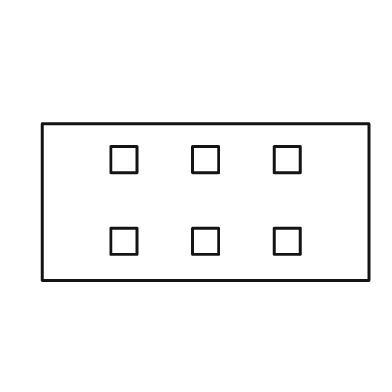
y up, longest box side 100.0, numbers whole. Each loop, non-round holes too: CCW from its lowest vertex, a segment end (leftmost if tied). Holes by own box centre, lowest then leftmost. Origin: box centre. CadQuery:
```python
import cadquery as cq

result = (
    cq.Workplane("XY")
    .moveTo(-50.0, -24.0)
    .lineTo(50.0, -24.0)
    .lineTo(50.0, 24.0)
    .lineTo(-50.0, 24.0)
    .close()
    .moveTo(-29.0, -16.0)
    .lineTo(-21.0, -16.0)
    .lineTo(-21.0, -8.0)
    .lineTo(-29.0, -8.0)
    .close()
    .moveTo(-4.0, -16.0)
    .lineTo(4.0, -16.0)
    .lineTo(4.0, -8.0)
    .lineTo(-4.0, -8.0)
    .close()
    .moveTo(21.0, -16.0)
    .lineTo(29.0, -16.0)
    .lineTo(29.0, -8.0)
    .lineTo(21.0, -8.0)
    .close()
    .moveTo(-29.0, 9.0)
    .lineTo(-21.0, 9.0)
    .lineTo(-21.0, 17.0)
    .lineTo(-29.0, 17.0)
    .close()
    .moveTo(-4.0, 9.0)
    .lineTo(4.0, 9.0)
    .lineTo(4.0, 17.0)
    .lineTo(-4.0, 17.0)
    .close()
    .moveTo(21.0, 9.0)
    .lineTo(29.0, 9.0)
    .lineTo(29.0, 17.0)
    .lineTo(21.0, 17.0)
    .close()
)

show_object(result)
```